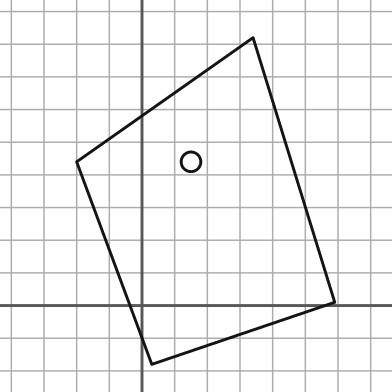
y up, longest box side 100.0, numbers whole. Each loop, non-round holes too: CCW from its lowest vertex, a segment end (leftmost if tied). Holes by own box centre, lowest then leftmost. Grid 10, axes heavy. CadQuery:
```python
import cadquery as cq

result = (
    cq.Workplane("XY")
    .moveTo(3.0, -18.0)
    .lineTo(59.0, 1.0)
    .lineTo(34.0, 82.0)
    .lineTo(-20.0, 44.0)
    .close()
    .moveTo(15.0, 44.0)
    .circle(3.0)
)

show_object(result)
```